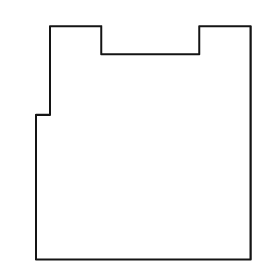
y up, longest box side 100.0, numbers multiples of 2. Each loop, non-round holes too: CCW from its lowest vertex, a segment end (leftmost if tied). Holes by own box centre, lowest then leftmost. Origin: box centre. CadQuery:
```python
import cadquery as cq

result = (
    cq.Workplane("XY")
    .moveTo(-46.0, -50.0)
    .lineTo(46.0, -50.0)
    .lineTo(46.0, 50.0)
    .lineTo(24.0, 50.0)
    .lineTo(24.0, 38.0)
    .lineTo(-18.0, 38.0)
    .lineTo(-18.0, 50.0)
    .lineTo(-40.0, 50.0)
    .lineTo(-40.0, 12.0)
    .lineTo(-46.0, 12.0)
    .close()
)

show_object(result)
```